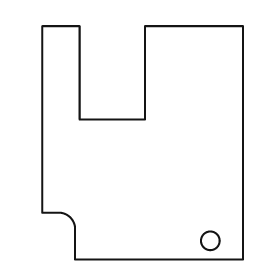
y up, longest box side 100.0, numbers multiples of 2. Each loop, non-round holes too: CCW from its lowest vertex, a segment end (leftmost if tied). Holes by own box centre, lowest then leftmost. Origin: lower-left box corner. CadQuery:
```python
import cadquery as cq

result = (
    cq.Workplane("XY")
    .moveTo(14.0, 0.0)
    .lineTo(86.0, 0.0)
    .lineTo(86.0, 100.0)
    .lineTo(44.0, 100.0)
    .lineTo(44.0, 60.0)
    .lineTo(16.0, 60.0)
    .lineTo(16.0, 100.0)
    .lineTo(0.0, 100.0)
    .lineTo(0.0, 20.0)
    .lineTo(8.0, 20.0)
    .threePointArc((12.0, 18.0), (14.0, 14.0))
    .close()
    .moveTo(72.0, 8.0)
    .circle(4.0)
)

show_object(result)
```